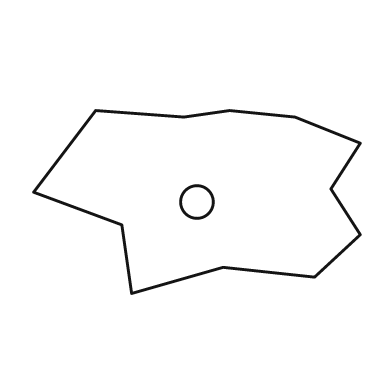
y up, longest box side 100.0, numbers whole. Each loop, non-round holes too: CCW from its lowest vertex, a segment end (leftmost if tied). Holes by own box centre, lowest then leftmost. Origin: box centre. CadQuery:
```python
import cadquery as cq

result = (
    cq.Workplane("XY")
    .moveTo(-20.0, -28.0)
    .lineTo(8.0, -20.0)
    .lineTo(36.0, -23.0)
    .lineTo(50.0, -10.0)
    .lineTo(41.0, 4.0)
    .lineTo(50.0, 18.0)
    .lineTo(30.0, 26.0)
    .lineTo(10.0, 28.0)
    .lineTo(-4.0, 26.0)
    .lineTo(-31.0, 28.0)
    .lineTo(-50.0, 3.0)
    .lineTo(-23.0, -7.0)
    .close()
    .moveTo(0.0, 0.0)
    .circle(5.0)
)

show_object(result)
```